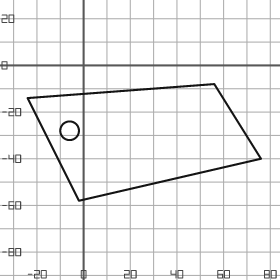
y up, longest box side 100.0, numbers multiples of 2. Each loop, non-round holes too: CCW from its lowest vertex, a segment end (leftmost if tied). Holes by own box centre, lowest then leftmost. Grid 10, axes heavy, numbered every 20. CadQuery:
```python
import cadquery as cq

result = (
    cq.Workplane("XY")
    .moveTo(-2.0, -58.0)
    .lineTo(76.0, -40.0)
    .lineTo(56.0, -8.0)
    .lineTo(-24.0, -14.0)
    .close()
    .moveTo(-6.0, -28.0)
    .circle(4.0)
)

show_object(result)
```